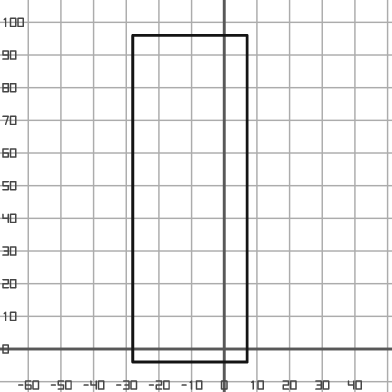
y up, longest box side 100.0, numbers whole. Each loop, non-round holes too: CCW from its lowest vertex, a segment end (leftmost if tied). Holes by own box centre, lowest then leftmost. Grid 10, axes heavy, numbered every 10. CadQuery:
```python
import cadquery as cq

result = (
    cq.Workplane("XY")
    .moveTo(-28.0, -4.0)
    .lineTo(7.0, -4.0)
    .lineTo(7.0, 96.0)
    .lineTo(-28.0, 96.0)
    .close()
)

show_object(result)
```